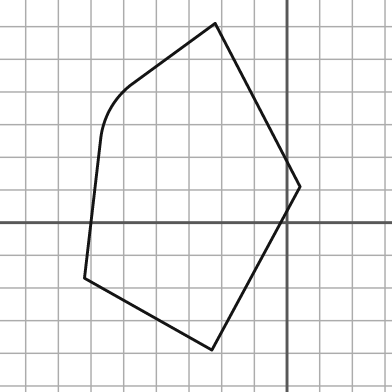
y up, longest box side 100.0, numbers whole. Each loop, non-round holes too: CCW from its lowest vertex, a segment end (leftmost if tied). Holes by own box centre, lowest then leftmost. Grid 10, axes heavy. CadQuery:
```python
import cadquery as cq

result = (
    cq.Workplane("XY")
    .moveTo(-23.0, -39.0)
    .lineTo(4.0, 11.0)
    .lineTo(-22.0, 61.0)
    .lineTo(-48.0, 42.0)
    .threePointArc((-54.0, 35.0), (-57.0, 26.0))
    .lineTo(-62.0, -17.0)
    .close()
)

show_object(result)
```